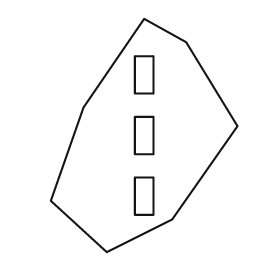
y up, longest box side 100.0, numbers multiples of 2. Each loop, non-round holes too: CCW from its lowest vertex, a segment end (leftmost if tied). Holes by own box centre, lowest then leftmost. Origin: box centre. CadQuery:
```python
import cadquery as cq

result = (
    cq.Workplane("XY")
    .moveTo(-16.0, -50.0)
    .lineTo(12.0, -36.0)
    .lineTo(40.0, 4.0)
    .lineTo(18.0, 40.0)
    .lineTo(0.0, 50.0)
    .lineTo(-26.0, 12.0)
    .lineTo(-40.0, -28.0)
    .close()
    .moveTo(-4.0, -34.0)
    .lineTo(4.0, -34.0)
    .lineTo(4.0, -18.0)
    .lineTo(-4.0, -18.0)
    .close()
    .moveTo(-4.0, -8.0)
    .lineTo(4.0, -8.0)
    .lineTo(4.0, 8.0)
    .lineTo(-4.0, 8.0)
    .close()
    .moveTo(-4.0, 18.0)
    .lineTo(4.0, 18.0)
    .lineTo(4.0, 34.0)
    .lineTo(-4.0, 34.0)
    .close()
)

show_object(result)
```